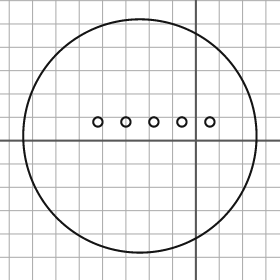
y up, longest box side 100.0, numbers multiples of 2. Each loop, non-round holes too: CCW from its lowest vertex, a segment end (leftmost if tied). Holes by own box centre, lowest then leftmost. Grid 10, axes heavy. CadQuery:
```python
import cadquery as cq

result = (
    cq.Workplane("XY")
    .moveTo(-24.0, 2.0)
    .circle(50.0)
    .moveTo(-42.0, 8.0)
    .circle(2.0)
    .moveTo(-30.0, 8.0)
    .circle(2.0)
    .moveTo(-18.0, 8.0)
    .circle(2.0)
    .moveTo(-6.0, 8.0)
    .circle(2.0)
    .moveTo(6.0, 8.0)
    .circle(2.0)
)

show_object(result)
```